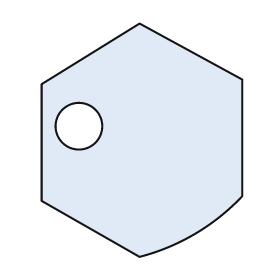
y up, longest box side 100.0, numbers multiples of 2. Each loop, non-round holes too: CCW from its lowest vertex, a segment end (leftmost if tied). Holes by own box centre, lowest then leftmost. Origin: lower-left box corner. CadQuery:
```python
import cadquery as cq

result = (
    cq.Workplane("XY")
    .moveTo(42.0, 0.0)
    .threePointArc((66.0, 10.0), (86.0, 26.0))
    .lineTo(86.0, 76.0)
    .lineTo(42.0, 100.0)
    .lineTo(0.0, 74.0)
    .lineTo(0.0, 24.0)
    .close()
    .moveTo(16.0, 56.0)
    .circle(10.0)
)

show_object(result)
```